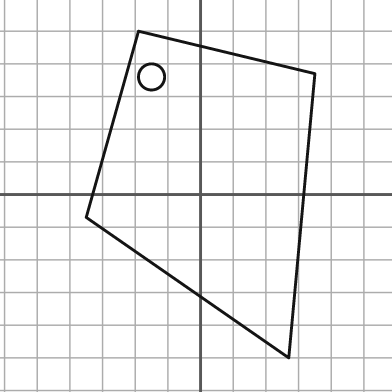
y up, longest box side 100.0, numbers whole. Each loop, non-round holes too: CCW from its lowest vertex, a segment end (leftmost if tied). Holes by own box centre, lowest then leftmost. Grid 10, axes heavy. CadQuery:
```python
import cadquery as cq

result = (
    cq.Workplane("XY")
    .moveTo(27.0, -50.0)
    .lineTo(35.0, 37.0)
    .lineTo(-19.0, 50.0)
    .lineTo(-35.0, -7.0)
    .close()
    .moveTo(-15.0, 36.0)
    .circle(4.0)
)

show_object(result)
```